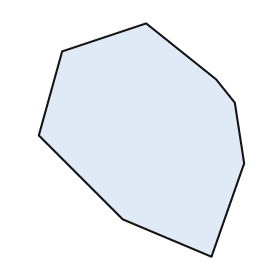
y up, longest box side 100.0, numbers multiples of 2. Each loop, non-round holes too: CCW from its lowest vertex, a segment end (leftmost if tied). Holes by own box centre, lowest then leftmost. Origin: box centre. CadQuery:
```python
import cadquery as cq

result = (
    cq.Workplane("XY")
    .moveTo(30.0, -50.0)
    .lineTo(44.0, -10.0)
    .lineTo(40.0, 16.0)
    .lineTo(32.0, 26.0)
    .lineTo(2.0, 50.0)
    .lineTo(-34.0, 38.0)
    .lineTo(-44.0, 2.0)
    .lineTo(-8.0, -34.0)
    .close()
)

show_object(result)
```